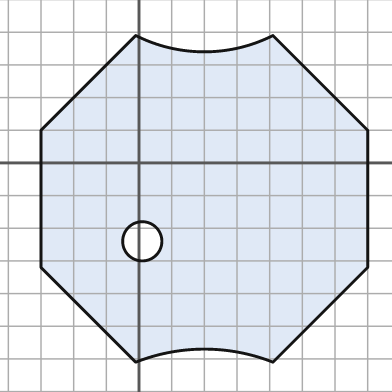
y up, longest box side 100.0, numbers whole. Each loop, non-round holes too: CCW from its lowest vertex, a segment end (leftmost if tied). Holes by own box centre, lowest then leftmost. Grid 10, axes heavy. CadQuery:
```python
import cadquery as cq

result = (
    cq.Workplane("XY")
    .moveTo(-1.0, -61.0)
    .threePointArc((20.0, -57.0), (41.0, -61.0))
    .lineTo(70.0, -32.0)
    .lineTo(70.0, 10.0)
    .lineTo(41.0, 39.0)
    .threePointArc((20.0, 34.0), (-1.0, 39.0))
    .lineTo(-30.0, 10.0)
    .lineTo(-30.0, -32.0)
    .close()
    .moveTo(1.0, -24.0)
    .circle(6.0)
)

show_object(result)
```